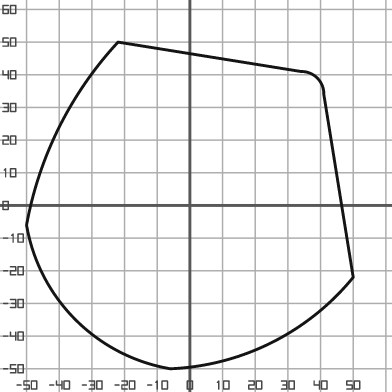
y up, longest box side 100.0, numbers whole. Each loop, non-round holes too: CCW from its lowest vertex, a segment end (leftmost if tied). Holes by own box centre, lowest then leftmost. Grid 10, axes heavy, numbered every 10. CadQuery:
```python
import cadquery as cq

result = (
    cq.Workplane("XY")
    .moveTo(-6.0, -50.0)
    .threePointArc((25.0, -42.0), (50.0, -22.0))
    .lineTo(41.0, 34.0)
    .threePointArc((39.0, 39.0), (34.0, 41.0))
    .lineTo(-22.0, 50.0)
    .threePointArc((-40.0, 24.0), (-50.0, -6.0))
    .threePointArc((-35.0, -35.0), (-6.0, -50.0))
    .close()
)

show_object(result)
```